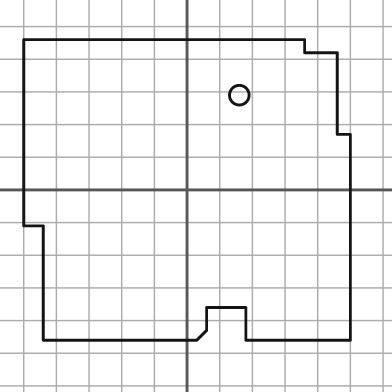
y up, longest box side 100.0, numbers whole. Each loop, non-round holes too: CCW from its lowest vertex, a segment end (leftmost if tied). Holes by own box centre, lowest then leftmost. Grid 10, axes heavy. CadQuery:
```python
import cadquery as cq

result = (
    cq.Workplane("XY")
    .moveTo(-44.0, -46.0)
    .lineTo(3.0, -46.0)
    .lineTo(6.0, -43.0)
    .lineTo(6.0, -36.0)
    .lineTo(18.0, -36.0)
    .lineTo(18.0, -46.0)
    .lineTo(50.0, -46.0)
    .lineTo(50.0, 17.0)
    .lineTo(46.0, 17.0)
    .lineTo(46.0, 42.0)
    .lineTo(36.0, 42.0)
    .lineTo(36.0, 46.0)
    .lineTo(-50.0, 46.0)
    .lineTo(-50.0, -11.0)
    .lineTo(-44.0, -11.0)
    .close()
    .moveTo(16.0, 29.0)
    .circle(3.0)
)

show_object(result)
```